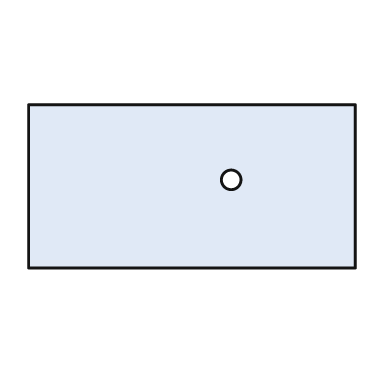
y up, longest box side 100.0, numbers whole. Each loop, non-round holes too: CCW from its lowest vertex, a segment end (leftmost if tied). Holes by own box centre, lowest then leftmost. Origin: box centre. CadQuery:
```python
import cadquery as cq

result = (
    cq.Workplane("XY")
    .moveTo(-50.0, -25.0)
    .lineTo(50.0, -25.0)
    .lineTo(50.0, 25.0)
    .lineTo(-50.0, 25.0)
    .close()
    .moveTo(12.0, 2.0)
    .circle(3.0)
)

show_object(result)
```